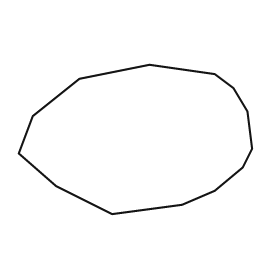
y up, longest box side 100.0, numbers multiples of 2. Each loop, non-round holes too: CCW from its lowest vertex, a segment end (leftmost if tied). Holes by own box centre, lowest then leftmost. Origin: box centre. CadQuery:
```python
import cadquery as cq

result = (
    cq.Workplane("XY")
    .moveTo(-10.0, -32.0)
    .lineTo(20.0, -28.0)
    .lineTo(34.0, -22.0)
    .lineTo(46.0, -12.0)
    .lineTo(50.0, -4.0)
    .lineTo(48.0, 12.0)
    .lineTo(42.0, 22.0)
    .lineTo(34.0, 28.0)
    .lineTo(6.0, 32.0)
    .lineTo(-24.0, 26.0)
    .lineTo(-44.0, 10.0)
    .lineTo(-50.0, -6.0)
    .lineTo(-34.0, -20.0)
    .close()
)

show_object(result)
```